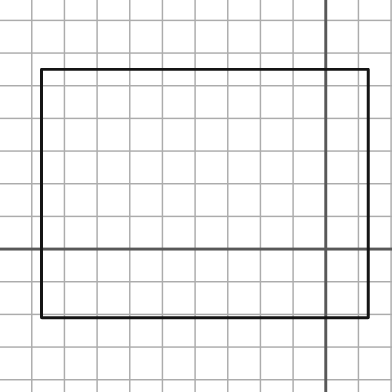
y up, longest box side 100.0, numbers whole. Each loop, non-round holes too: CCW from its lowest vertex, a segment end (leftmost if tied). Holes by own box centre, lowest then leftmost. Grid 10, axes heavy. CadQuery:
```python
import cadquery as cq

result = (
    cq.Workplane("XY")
    .moveTo(-87.0, -21.0)
    .lineTo(13.0, -21.0)
    .lineTo(13.0, 55.0)
    .lineTo(-87.0, 55.0)
    .close()
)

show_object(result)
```